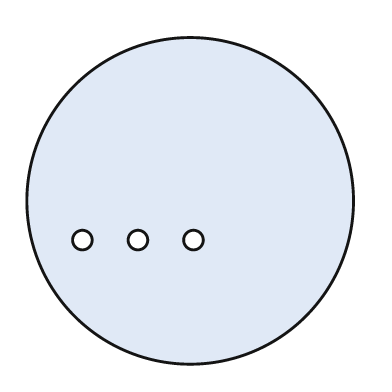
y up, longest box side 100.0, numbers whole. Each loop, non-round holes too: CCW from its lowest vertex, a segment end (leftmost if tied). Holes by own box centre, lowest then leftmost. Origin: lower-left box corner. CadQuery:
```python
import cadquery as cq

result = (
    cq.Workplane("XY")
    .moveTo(50.0, 50.0)
    .circle(50.0)
    .moveTo(17.0, 38.0)
    .circle(3.0)
    .moveTo(34.0, 38.0)
    .circle(3.0)
    .moveTo(51.0, 38.0)
    .circle(3.0)
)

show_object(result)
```